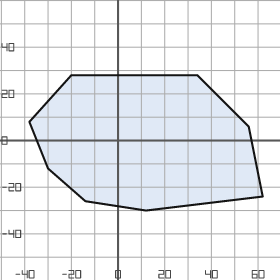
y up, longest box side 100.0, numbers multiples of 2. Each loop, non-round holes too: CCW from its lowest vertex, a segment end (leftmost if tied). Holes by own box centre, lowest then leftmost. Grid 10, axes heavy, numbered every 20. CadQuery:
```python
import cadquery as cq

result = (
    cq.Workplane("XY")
    .moveTo(12.0, -30.0)
    .lineTo(62.0, -24.0)
    .lineTo(56.0, 6.0)
    .lineTo(34.0, 28.0)
    .lineTo(-20.0, 28.0)
    .lineTo(-38.0, 8.0)
    .lineTo(-30.0, -12.0)
    .lineTo(-14.0, -26.0)
    .close()
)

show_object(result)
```